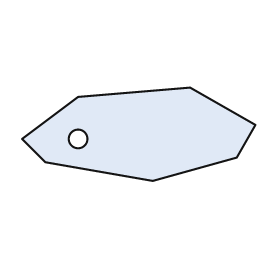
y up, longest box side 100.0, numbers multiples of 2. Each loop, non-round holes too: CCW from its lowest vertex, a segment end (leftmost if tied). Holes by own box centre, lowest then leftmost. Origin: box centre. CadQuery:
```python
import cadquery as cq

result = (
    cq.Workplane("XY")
    .moveTo(6.0, -20.0)
    .lineTo(42.0, -10.0)
    .lineTo(50.0, 4.0)
    .lineTo(22.0, 20.0)
    .lineTo(-26.0, 16.0)
    .lineTo(-50.0, -2.0)
    .lineTo(-40.0, -12.0)
    .close()
    .moveTo(-26.0, -2.0)
    .circle(4.0)
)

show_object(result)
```